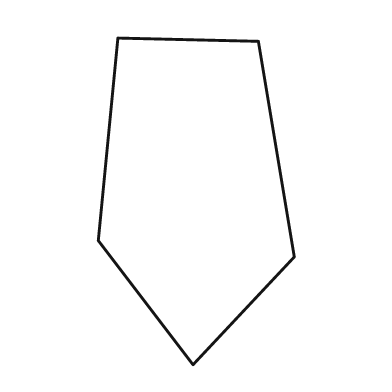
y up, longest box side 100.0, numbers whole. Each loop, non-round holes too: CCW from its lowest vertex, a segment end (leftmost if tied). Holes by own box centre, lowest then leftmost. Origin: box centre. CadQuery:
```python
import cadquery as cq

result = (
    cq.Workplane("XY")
    .moveTo(-1.0, -50.0)
    .lineTo(30.0, -17.0)
    .lineTo(19.0, 49.0)
    .lineTo(-24.0, 50.0)
    .lineTo(-30.0, -12.0)
    .close()
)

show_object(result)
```